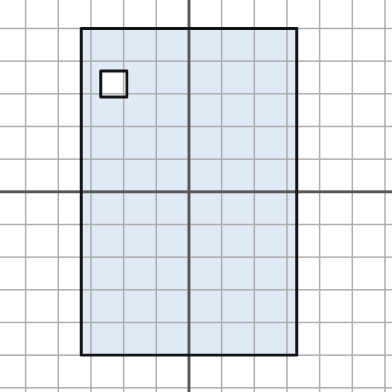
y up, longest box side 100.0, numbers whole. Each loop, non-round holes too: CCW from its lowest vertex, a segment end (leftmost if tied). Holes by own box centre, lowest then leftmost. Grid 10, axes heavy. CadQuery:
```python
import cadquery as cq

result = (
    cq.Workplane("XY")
    .moveTo(-33.0, -50.0)
    .lineTo(33.0, -50.0)
    .lineTo(33.0, 50.0)
    .lineTo(-33.0, 50.0)
    .close()
    .moveTo(-27.0, 29.0)
    .lineTo(-19.0, 29.0)
    .lineTo(-19.0, 37.0)
    .lineTo(-27.0, 37.0)
    .close()
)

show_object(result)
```